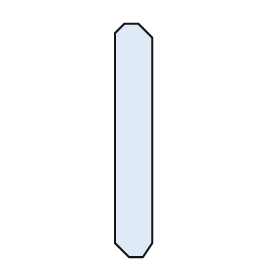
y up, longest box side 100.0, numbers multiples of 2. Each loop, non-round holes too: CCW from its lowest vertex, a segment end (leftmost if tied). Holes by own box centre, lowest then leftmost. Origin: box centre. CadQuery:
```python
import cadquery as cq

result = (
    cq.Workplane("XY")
    .moveTo(-2.0, -50.0)
    .lineTo(4.0, -50.0)
    .lineTo(8.0, -44.0)
    .lineTo(8.0, 44.0)
    .lineTo(2.0, 50.0)
    .lineTo(-4.0, 50.0)
    .lineTo(-8.0, 46.0)
    .lineTo(-8.0, -44.0)
    .close()
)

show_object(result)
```